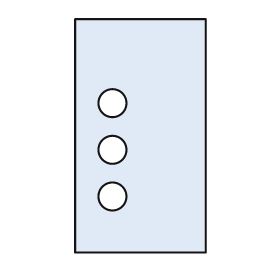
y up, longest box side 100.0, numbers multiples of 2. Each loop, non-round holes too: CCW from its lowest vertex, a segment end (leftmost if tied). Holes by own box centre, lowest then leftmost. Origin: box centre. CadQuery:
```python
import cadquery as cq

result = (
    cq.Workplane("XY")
    .moveTo(-28.0, -50.0)
    .lineTo(28.0, -50.0)
    .lineTo(28.0, 50.0)
    .lineTo(-28.0, 50.0)
    .close()
    .moveTo(-12.0, -26.0)
    .circle(6.0)
    .moveTo(-12.0, -6.0)
    .circle(6.0)
    .moveTo(-12.0, 14.0)
    .circle(6.0)
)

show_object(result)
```